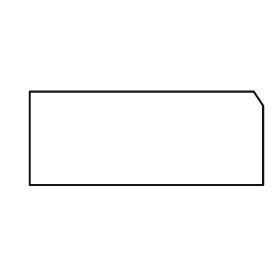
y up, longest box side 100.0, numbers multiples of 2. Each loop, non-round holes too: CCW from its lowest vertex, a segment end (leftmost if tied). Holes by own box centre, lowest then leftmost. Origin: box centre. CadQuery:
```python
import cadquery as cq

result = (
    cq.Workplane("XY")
    .moveTo(-50.0, -20.0)
    .lineTo(50.0, -20.0)
    .lineTo(50.0, 14.0)
    .lineTo(46.0, 20.0)
    .lineTo(-50.0, 20.0)
    .close()
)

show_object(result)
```